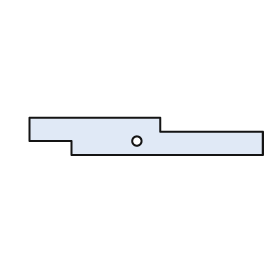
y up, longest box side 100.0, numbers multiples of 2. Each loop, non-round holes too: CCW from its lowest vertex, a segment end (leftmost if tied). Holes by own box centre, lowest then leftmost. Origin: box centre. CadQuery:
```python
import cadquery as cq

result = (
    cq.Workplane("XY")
    .moveTo(-32.0, -8.0)
    .lineTo(50.0, -8.0)
    .lineTo(50.0, 2.0)
    .lineTo(6.0, 2.0)
    .lineTo(6.0, 8.0)
    .lineTo(-50.0, 8.0)
    .lineTo(-50.0, -2.0)
    .lineTo(-32.0, -2.0)
    .close()
    .moveTo(-4.0, -2.0)
    .circle(2.0)
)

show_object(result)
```